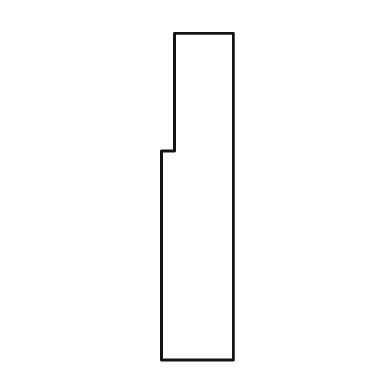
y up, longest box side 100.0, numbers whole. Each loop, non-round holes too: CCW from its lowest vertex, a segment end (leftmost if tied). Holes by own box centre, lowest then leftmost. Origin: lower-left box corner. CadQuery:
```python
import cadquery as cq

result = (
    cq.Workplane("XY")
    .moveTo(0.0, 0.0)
    .lineTo(22.0, 0.0)
    .lineTo(22.0, 100.0)
    .lineTo(4.0, 100.0)
    .lineTo(4.0, 64.0)
    .lineTo(0.0, 64.0)
    .close()
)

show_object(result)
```